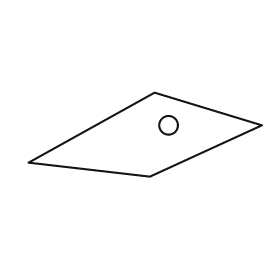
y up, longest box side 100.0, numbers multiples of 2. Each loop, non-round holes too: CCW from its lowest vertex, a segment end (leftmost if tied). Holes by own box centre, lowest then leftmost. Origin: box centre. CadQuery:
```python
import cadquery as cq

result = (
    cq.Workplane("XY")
    .moveTo(2.0, -18.0)
    .lineTo(50.0, 4.0)
    .lineTo(4.0, 18.0)
    .lineTo(-50.0, -12.0)
    .close()
    .moveTo(10.0, 4.0)
    .circle(4.0)
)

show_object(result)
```